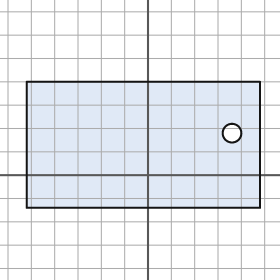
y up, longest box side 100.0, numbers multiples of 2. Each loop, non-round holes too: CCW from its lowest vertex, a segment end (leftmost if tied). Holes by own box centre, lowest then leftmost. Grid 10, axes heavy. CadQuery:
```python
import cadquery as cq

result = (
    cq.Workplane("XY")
    .moveTo(-52.0, -14.0)
    .lineTo(48.0, -14.0)
    .lineTo(48.0, 40.0)
    .lineTo(-52.0, 40.0)
    .close()
    .moveTo(36.0, 18.0)
    .circle(4.0)
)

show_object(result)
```